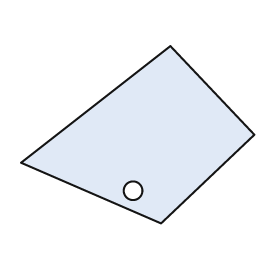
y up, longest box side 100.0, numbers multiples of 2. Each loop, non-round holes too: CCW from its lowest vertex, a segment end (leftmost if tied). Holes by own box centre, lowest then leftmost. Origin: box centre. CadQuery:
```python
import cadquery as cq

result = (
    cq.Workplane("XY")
    .moveTo(10.0, -38.0)
    .lineTo(50.0, 0.0)
    .lineTo(14.0, 38.0)
    .lineTo(-50.0, -12.0)
    .close()
    .moveTo(-2.0, -24.0)
    .circle(4.0)
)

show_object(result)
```